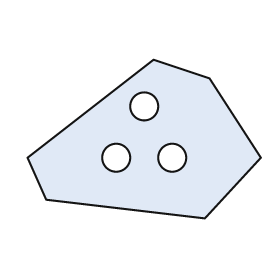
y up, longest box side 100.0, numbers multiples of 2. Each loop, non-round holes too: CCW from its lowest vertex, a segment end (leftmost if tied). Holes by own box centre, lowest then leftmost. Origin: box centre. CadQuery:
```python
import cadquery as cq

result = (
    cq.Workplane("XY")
    .moveTo(26.0, -34.0)
    .lineTo(50.0, -8.0)
    .lineTo(28.0, 26.0)
    .lineTo(4.0, 34.0)
    .lineTo(-50.0, -8.0)
    .lineTo(-42.0, -26.0)
    .close()
    .moveTo(-12.0, -8.0)
    .circle(6.0)
    .moveTo(12.0, -8.0)
    .circle(6.0)
    .moveTo(0.0, 14.0)
    .circle(6.0)
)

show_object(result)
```